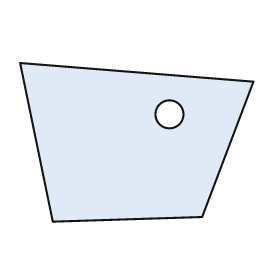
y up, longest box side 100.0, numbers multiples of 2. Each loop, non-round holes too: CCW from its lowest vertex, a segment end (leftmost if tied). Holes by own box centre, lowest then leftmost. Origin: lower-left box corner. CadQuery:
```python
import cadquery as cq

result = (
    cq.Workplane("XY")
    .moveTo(14.0, 0.0)
    .lineTo(78.0, 2.0)
    .lineTo(100.0, 60.0)
    .lineTo(0.0, 68.0)
    .close()
    .moveTo(64.0, 46.0)
    .circle(6.0)
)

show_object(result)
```